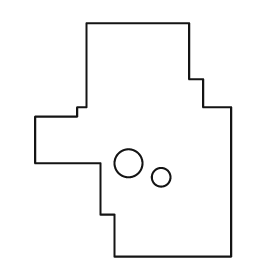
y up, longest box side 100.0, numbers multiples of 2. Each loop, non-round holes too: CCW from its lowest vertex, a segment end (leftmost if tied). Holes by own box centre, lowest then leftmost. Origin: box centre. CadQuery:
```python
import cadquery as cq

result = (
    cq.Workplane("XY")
    .moveTo(-8.0, -50.0)
    .lineTo(42.0, -50.0)
    .lineTo(42.0, 14.0)
    .lineTo(30.0, 14.0)
    .lineTo(30.0, 26.0)
    .lineTo(24.0, 26.0)
    .lineTo(24.0, 50.0)
    .lineTo(-20.0, 50.0)
    .lineTo(-20.0, 14.0)
    .lineTo(-24.0, 14.0)
    .lineTo(-24.0, 10.0)
    .lineTo(-42.0, 10.0)
    .lineTo(-42.0, -10.0)
    .lineTo(-14.0, -10.0)
    .lineTo(-14.0, -32.0)
    .lineTo(-8.0, -32.0)
    .close()
    .moveTo(12.0, -16.0)
    .circle(4.0)
    .moveTo(-2.0, -10.0)
    .circle(6.0)
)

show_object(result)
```